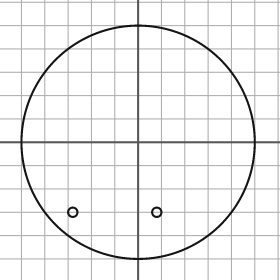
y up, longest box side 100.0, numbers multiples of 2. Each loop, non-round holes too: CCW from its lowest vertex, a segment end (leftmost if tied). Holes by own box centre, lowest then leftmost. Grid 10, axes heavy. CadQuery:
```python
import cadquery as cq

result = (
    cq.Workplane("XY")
    .moveTo(0.0, 0.0)
    .circle(50.0)
    .moveTo(-28.0, -30.0)
    .circle(2.0)
    .moveTo(8.0, -30.0)
    .circle(2.0)
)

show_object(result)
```